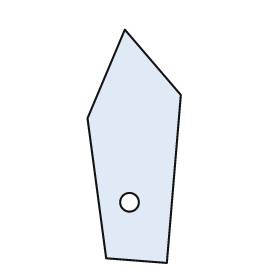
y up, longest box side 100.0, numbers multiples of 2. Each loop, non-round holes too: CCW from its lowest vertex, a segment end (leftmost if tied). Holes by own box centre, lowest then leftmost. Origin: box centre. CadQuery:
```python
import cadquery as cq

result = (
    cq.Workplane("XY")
    .moveTo(14.0, -50.0)
    .lineTo(20.0, 22.0)
    .lineTo(-4.0, 50.0)
    .lineTo(-20.0, 12.0)
    .lineTo(-12.0, -48.0)
    .close()
    .moveTo(-2.0, -24.0)
    .circle(4.0)
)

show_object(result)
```